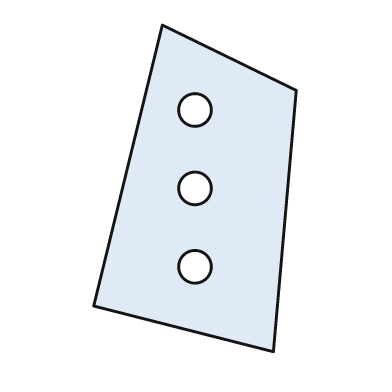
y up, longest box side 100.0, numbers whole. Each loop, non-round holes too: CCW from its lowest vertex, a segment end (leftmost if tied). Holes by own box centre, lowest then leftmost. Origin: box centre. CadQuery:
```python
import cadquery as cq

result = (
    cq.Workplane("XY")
    .moveTo(24.0, -50.0)
    .lineTo(31.0, 30.0)
    .lineTo(-10.0, 50.0)
    .lineTo(-31.0, -36.0)
    .close()
    .moveTo(0.0, -24.0)
    .circle(5.0)
    .moveTo(0.0, 0.0)
    .circle(5.0)
    .moveTo(0.0, 24.0)
    .circle(5.0)
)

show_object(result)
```